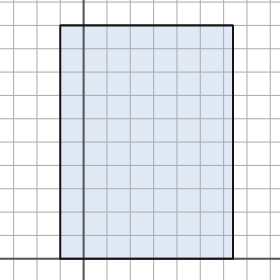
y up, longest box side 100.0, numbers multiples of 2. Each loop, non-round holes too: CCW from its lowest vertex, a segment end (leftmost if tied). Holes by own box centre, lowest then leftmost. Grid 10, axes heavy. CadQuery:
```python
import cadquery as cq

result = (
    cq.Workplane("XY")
    .moveTo(-10.0, 0.0)
    .lineTo(64.0, 0.0)
    .lineTo(64.0, 100.0)
    .lineTo(-10.0, 100.0)
    .close()
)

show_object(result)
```